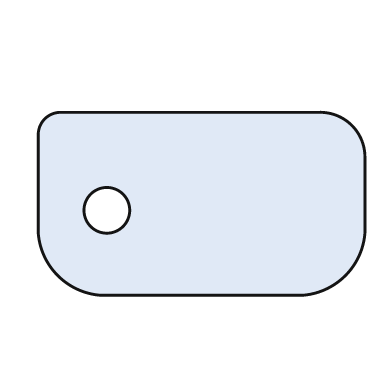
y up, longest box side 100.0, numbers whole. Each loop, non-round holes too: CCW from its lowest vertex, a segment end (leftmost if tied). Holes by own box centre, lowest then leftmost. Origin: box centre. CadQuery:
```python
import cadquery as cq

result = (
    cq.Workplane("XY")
    .moveTo(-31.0, -28.0)
    .lineTo(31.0, -28.0)
    .threePointArc((44.0, -22.0), (50.0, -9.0))
    .lineTo(50.0, 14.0)
    .threePointArc((46.0, 24.0), (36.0, 28.0))
    .lineTo(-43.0, 28.0)
    .threePointArc((-48.0, 26.0), (-50.0, 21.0))
    .lineTo(-50.0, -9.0)
    .threePointArc((-44.0, -22.0), (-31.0, -28.0))
    .close()
    .moveTo(-29.0, -2.0)
    .circle(7.0)
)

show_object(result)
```